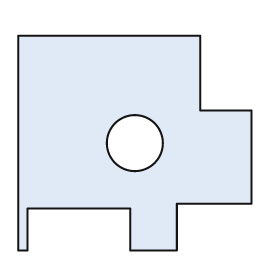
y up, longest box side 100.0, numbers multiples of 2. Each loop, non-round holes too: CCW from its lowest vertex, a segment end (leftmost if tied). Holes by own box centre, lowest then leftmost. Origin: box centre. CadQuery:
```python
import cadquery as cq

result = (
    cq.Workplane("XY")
    .moveTo(-50.0, -46.0)
    .lineTo(-46.0, -46.0)
    .lineTo(-46.0, -28.0)
    .lineTo(-2.0, -28.0)
    .lineTo(-2.0, -46.0)
    .lineTo(18.0, -46.0)
    .lineTo(18.0, -26.0)
    .lineTo(50.0, -26.0)
    .lineTo(50.0, 14.0)
    .lineTo(28.0, 14.0)
    .lineTo(28.0, 46.0)
    .lineTo(-50.0, 46.0)
    .close()
    .moveTo(0.0, 0.0)
    .circle(12.0)
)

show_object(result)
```